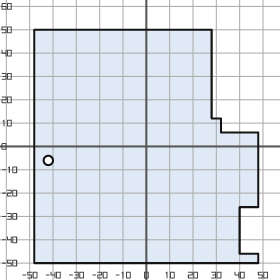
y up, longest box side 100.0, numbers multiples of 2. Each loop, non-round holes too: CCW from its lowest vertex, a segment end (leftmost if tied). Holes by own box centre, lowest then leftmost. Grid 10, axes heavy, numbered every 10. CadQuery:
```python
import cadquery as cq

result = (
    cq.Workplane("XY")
    .moveTo(-48.0, -50.0)
    .lineTo(48.0, -50.0)
    .lineTo(48.0, -46.0)
    .lineTo(40.0, -46.0)
    .lineTo(40.0, -26.0)
    .lineTo(48.0, -26.0)
    .lineTo(48.0, 6.0)
    .lineTo(32.0, 6.0)
    .lineTo(32.0, 12.0)
    .lineTo(28.0, 12.0)
    .lineTo(28.0, 50.0)
    .lineTo(-48.0, 50.0)
    .close()
    .moveTo(-42.0, -6.0)
    .circle(2.0)
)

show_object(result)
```